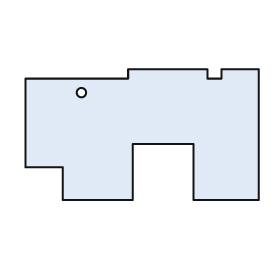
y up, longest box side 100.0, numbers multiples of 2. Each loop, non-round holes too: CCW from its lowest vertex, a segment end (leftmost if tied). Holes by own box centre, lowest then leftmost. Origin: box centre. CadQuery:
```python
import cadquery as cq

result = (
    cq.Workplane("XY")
    .moveTo(-34.0, -28.0)
    .lineTo(-4.0, -28.0)
    .lineTo(-4.0, -4.0)
    .lineTo(22.0, -4.0)
    .lineTo(22.0, -28.0)
    .lineTo(50.0, -28.0)
    .lineTo(50.0, 28.0)
    .lineTo(34.0, 28.0)
    .lineTo(34.0, 24.0)
    .lineTo(28.0, 24.0)
    .lineTo(28.0, 28.0)
    .lineTo(-6.0, 28.0)
    .lineTo(-6.0, 24.0)
    .lineTo(-50.0, 24.0)
    .lineTo(-50.0, -14.0)
    .lineTo(-34.0, -14.0)
    .close()
    .moveTo(-26.0, 18.0)
    .circle(2.0)
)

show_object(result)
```